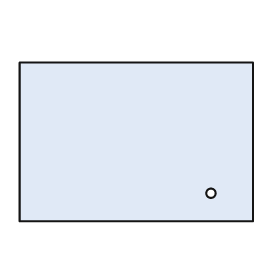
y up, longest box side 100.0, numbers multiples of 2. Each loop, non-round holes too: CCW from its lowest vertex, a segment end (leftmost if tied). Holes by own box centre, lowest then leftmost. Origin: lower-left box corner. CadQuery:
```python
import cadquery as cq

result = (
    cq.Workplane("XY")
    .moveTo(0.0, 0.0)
    .lineTo(100.0, 0.0)
    .lineTo(100.0, 68.0)
    .lineTo(0.0, 68.0)
    .close()
    .moveTo(82.0, 12.0)
    .circle(2.0)
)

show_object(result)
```